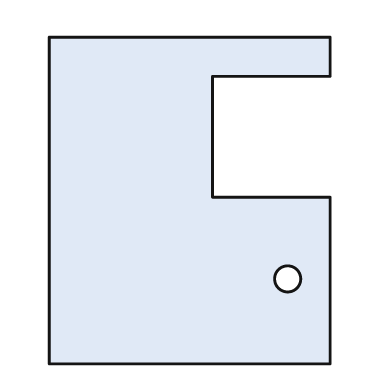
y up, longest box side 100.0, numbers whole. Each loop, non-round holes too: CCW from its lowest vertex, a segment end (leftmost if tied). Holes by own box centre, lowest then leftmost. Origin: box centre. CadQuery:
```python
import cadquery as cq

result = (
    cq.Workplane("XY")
    .moveTo(-43.0, -50.0)
    .lineTo(43.0, -50.0)
    .lineTo(43.0, 1.0)
    .lineTo(7.0, 1.0)
    .lineTo(7.0, 38.0)
    .lineTo(43.0, 38.0)
    .lineTo(43.0, 50.0)
    .lineTo(-43.0, 50.0)
    .close()
    .moveTo(30.0, -24.0)
    .circle(4.0)
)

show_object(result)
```